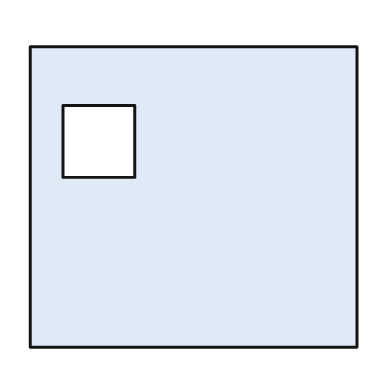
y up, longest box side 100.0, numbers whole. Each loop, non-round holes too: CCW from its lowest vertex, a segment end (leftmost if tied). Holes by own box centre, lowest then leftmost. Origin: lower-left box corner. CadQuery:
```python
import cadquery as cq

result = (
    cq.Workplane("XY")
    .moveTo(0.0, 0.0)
    .lineTo(100.0, 0.0)
    .lineTo(100.0, 92.0)
    .lineTo(0.0, 92.0)
    .close()
    .moveTo(10.0, 52.0)
    .lineTo(32.0, 52.0)
    .lineTo(32.0, 74.0)
    .lineTo(10.0, 74.0)
    .close()
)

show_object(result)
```